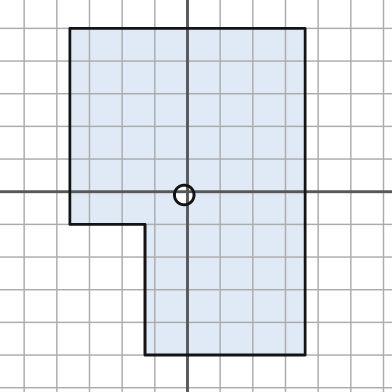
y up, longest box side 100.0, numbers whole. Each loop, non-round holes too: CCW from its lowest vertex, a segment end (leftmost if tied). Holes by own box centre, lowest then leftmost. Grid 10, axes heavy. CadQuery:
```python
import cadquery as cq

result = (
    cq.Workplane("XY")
    .moveTo(-13.0, -50.0)
    .lineTo(36.0, -50.0)
    .lineTo(36.0, 50.0)
    .lineTo(-36.0, 50.0)
    .lineTo(-36.0, -10.0)
    .lineTo(-13.0, -10.0)
    .close()
    .moveTo(-1.0, -1.0)
    .circle(3.0)
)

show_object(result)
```